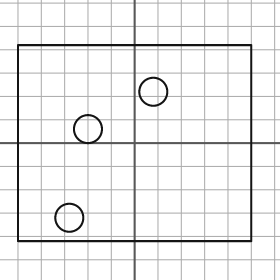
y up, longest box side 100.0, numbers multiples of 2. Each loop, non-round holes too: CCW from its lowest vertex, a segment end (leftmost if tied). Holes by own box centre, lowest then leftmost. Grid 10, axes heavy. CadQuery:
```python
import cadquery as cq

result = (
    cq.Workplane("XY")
    .moveTo(-50.0, -42.0)
    .lineTo(50.0, -42.0)
    .lineTo(50.0, 42.0)
    .lineTo(-50.0, 42.0)
    .close()
    .moveTo(-28.0, -32.0)
    .circle(6.0)
    .moveTo(-20.0, 6.0)
    .circle(6.0)
    .moveTo(8.0, 22.0)
    .circle(6.0)
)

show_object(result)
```